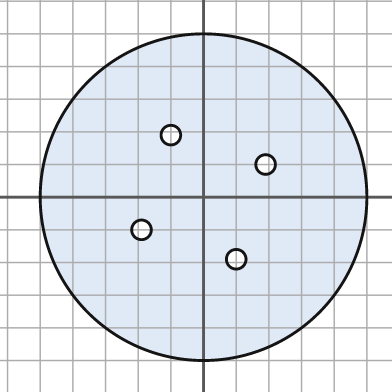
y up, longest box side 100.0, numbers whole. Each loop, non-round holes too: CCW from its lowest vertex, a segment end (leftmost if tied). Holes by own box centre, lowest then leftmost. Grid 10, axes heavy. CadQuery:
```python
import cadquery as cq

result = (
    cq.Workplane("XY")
    .moveTo(0.0, 0.0)
    .circle(50.0)
    .moveTo(10.0, -19.0)
    .circle(3.0)
    .moveTo(-19.0, -10.0)
    .circle(3.0)
    .moveTo(19.0, 10.0)
    .circle(3.0)
    .moveTo(-10.0, 19.0)
    .circle(3.0)
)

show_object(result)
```